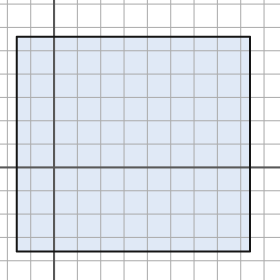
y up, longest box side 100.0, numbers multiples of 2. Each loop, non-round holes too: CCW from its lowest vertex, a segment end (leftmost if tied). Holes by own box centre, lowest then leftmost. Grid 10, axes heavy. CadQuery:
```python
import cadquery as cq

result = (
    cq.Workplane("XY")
    .moveTo(-16.0, -36.0)
    .lineTo(84.0, -36.0)
    .lineTo(84.0, 56.0)
    .lineTo(-16.0, 56.0)
    .close()
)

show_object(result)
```